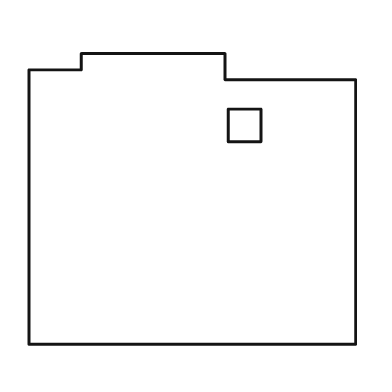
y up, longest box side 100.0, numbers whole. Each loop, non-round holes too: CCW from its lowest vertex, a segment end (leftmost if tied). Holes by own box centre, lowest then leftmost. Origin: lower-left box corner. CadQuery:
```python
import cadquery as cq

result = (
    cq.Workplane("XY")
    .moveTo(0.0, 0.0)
    .lineTo(100.0, 0.0)
    .lineTo(100.0, 81.0)
    .lineTo(60.0, 81.0)
    .lineTo(60.0, 89.0)
    .lineTo(16.0, 89.0)
    .lineTo(16.0, 84.0)
    .lineTo(0.0, 84.0)
    .close()
    .moveTo(61.0, 62.0)
    .lineTo(71.0, 62.0)
    .lineTo(71.0, 72.0)
    .lineTo(61.0, 72.0)
    .close()
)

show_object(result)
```